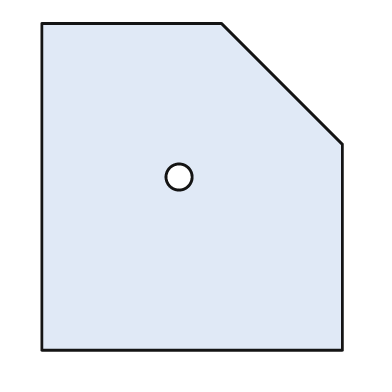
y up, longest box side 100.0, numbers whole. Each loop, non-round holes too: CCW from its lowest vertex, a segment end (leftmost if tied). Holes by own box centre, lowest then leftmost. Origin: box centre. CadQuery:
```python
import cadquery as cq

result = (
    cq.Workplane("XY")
    .moveTo(-46.0, -50.0)
    .lineTo(46.0, -50.0)
    .lineTo(46.0, 13.0)
    .lineTo(9.0, 50.0)
    .lineTo(-46.0, 50.0)
    .close()
    .moveTo(-4.0, 3.0)
    .circle(4.0)
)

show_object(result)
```